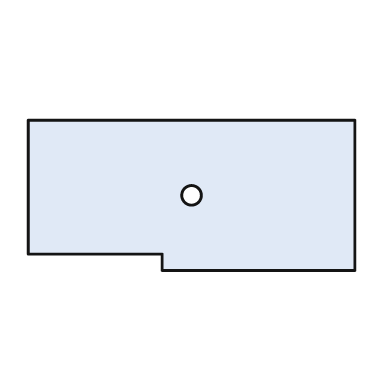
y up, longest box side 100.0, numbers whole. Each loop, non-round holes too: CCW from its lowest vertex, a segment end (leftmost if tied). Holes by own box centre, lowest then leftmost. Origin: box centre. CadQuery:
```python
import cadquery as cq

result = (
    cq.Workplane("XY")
    .moveTo(-9.0, -23.0)
    .lineTo(50.0, -23.0)
    .lineTo(50.0, 23.0)
    .lineTo(-50.0, 23.0)
    .lineTo(-50.0, -18.0)
    .lineTo(-9.0, -18.0)
    .close()
    .moveTo(0.0, 0.0)
    .circle(3.0)
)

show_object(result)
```